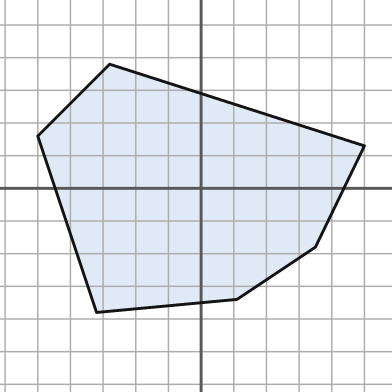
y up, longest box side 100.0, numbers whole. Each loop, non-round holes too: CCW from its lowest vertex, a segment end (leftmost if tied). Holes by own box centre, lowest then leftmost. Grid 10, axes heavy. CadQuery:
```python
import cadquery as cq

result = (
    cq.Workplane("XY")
    .moveTo(-32.0, -38.0)
    .lineTo(11.0, -34.0)
    .lineTo(35.0, -18.0)
    .lineTo(50.0, 13.0)
    .lineTo(-28.0, 38.0)
    .lineTo(-50.0, 16.0)
    .close()
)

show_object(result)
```